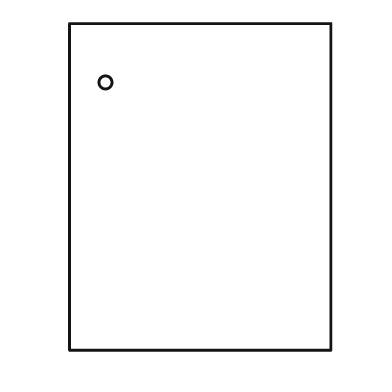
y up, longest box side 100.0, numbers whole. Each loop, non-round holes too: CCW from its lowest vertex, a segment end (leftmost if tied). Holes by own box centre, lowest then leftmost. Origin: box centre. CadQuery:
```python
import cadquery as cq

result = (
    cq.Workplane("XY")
    .moveTo(-40.0, -50.0)
    .lineTo(40.0, -50.0)
    .lineTo(40.0, 50.0)
    .lineTo(-40.0, 50.0)
    .close()
    .moveTo(-29.0, 32.0)
    .circle(2.0)
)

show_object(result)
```